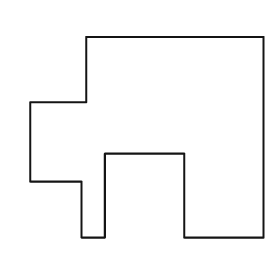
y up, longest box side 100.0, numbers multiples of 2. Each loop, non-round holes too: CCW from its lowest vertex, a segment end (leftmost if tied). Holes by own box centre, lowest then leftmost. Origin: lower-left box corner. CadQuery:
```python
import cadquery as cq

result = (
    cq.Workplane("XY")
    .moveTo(22.0, 0.0)
    .lineTo(32.0, 0.0)
    .lineTo(32.0, 36.0)
    .lineTo(66.0, 36.0)
    .lineTo(66.0, 0.0)
    .lineTo(100.0, 0.0)
    .lineTo(100.0, 86.0)
    .lineTo(24.0, 86.0)
    .lineTo(24.0, 58.0)
    .lineTo(0.0, 58.0)
    .lineTo(0.0, 24.0)
    .lineTo(22.0, 24.0)
    .close()
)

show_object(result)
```